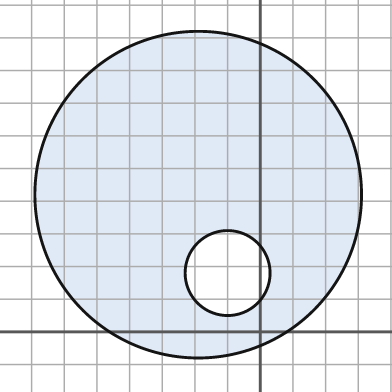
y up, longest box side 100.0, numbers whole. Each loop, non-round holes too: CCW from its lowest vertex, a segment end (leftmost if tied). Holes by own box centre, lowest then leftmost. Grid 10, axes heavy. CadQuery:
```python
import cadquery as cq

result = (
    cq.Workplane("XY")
    .moveTo(-19.0, 42.0)
    .circle(50.0)
    .moveTo(-10.0, 18.0)
    .circle(13.0)
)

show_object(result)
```